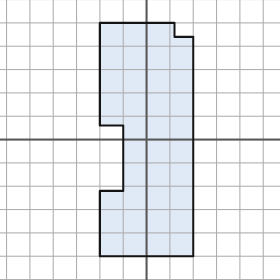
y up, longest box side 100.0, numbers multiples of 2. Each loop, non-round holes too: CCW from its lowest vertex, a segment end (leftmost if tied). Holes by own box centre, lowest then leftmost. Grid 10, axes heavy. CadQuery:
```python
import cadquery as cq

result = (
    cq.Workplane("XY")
    .moveTo(-20.0, -50.0)
    .lineTo(20.0, -50.0)
    .lineTo(20.0, 44.0)
    .lineTo(12.0, 44.0)
    .lineTo(12.0, 50.0)
    .lineTo(-20.0, 50.0)
    .lineTo(-20.0, 6.0)
    .lineTo(-10.0, 6.0)
    .lineTo(-10.0, -22.0)
    .lineTo(-20.0, -22.0)
    .close()
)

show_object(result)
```